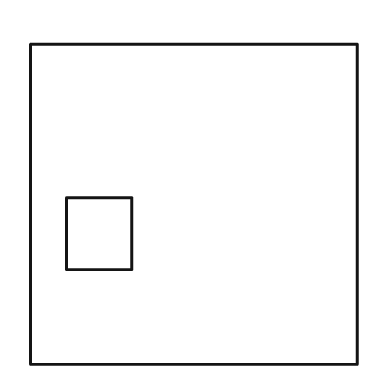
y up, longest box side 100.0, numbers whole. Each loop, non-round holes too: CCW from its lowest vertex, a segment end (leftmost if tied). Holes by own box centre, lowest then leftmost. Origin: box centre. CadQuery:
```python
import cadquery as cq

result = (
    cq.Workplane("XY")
    .moveTo(-50.0, -49.0)
    .lineTo(50.0, -49.0)
    .lineTo(50.0, 49.0)
    .lineTo(-50.0, 49.0)
    .close()
    .moveTo(-39.0, -20.0)
    .lineTo(-19.0, -20.0)
    .lineTo(-19.0, 2.0)
    .lineTo(-39.0, 2.0)
    .close()
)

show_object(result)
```